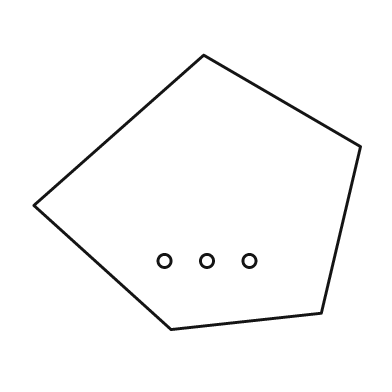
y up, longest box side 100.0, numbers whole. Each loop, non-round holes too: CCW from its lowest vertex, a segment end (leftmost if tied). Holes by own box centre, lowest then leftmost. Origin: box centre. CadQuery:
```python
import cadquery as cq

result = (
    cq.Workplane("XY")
    .moveTo(-8.0, -42.0)
    .lineTo(38.0, -37.0)
    .lineTo(50.0, 14.0)
    .lineTo(2.0, 42.0)
    .lineTo(-50.0, -4.0)
    .close()
    .moveTo(-10.0, -21.0)
    .circle(2.0)
    .moveTo(3.0, -21.0)
    .circle(2.0)
    .moveTo(16.0, -21.0)
    .circle(2.0)
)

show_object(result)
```